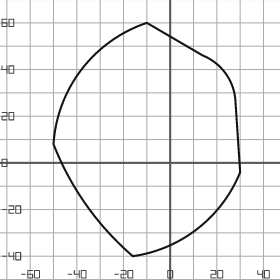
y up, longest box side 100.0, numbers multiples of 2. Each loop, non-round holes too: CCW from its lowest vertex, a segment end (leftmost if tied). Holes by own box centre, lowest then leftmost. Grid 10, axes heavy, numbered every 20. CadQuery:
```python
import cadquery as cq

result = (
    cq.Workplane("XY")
    .moveTo(-16.0, -40.0)
    .threePointArc((12.0, -28.0), (30.0, -4.0))
    .lineTo(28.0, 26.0)
    .threePointArc((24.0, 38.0), (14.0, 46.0))
    .lineTo(-10.0, 60.0)
    .threePointArc((-38.0, 40.0), (-50.0, 8.0))
    .threePointArc((-36.0, -18.0), (-16.0, -40.0))
    .close()
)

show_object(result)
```